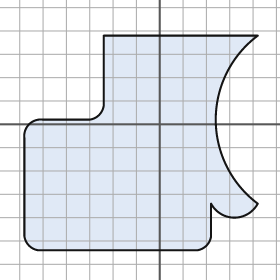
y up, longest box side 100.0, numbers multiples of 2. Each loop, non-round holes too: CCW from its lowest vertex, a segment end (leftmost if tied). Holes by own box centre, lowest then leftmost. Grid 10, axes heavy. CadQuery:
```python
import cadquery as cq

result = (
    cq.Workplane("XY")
    .moveTo(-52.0, -54.0)
    .lineTo(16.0, -54.0)
    .threePointArc((20.0, -52.0), (22.0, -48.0))
    .lineTo(22.0, -34.0)
    .threePointArc((32.0, -40.0), (42.0, -34.0))
    .threePointArc((24.0, 2.0), (42.0, 38.0))
    .lineTo(-24.0, 38.0)
    .lineTo(-24.0, 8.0)
    .threePointArc((-26.0, 4.0), (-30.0, 2.0))
    .lineTo(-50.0, 2.0)
    .threePointArc((-56.0, 0.0), (-58.0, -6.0))
    .lineTo(-58.0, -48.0)
    .threePointArc((-56.0, -52.0), (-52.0, -54.0))
    .close()
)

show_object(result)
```